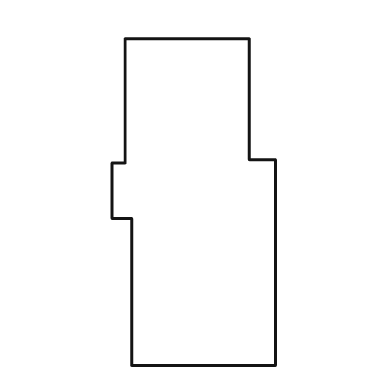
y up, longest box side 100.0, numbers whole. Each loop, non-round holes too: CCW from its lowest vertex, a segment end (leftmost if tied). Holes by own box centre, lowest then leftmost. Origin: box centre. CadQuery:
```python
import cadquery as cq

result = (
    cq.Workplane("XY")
    .moveTo(-19.0, -50.0)
    .lineTo(25.0, -50.0)
    .lineTo(25.0, 13.0)
    .lineTo(17.0, 13.0)
    .lineTo(17.0, 50.0)
    .lineTo(-21.0, 50.0)
    .lineTo(-21.0, 12.0)
    .lineTo(-25.0, 12.0)
    .lineTo(-25.0, -5.0)
    .lineTo(-19.0, -5.0)
    .close()
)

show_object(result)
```